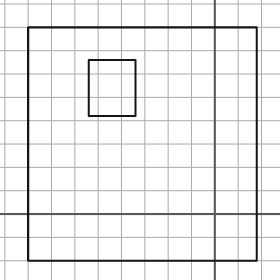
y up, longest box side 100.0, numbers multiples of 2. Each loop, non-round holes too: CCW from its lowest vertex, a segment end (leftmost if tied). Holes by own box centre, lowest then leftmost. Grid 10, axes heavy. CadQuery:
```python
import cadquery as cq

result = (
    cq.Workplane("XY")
    .moveTo(-80.0, -20.0)
    .lineTo(18.0, -20.0)
    .lineTo(18.0, 80.0)
    .lineTo(-80.0, 80.0)
    .close()
    .moveTo(-54.0, 42.0)
    .lineTo(-34.0, 42.0)
    .lineTo(-34.0, 66.0)
    .lineTo(-54.0, 66.0)
    .close()
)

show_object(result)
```